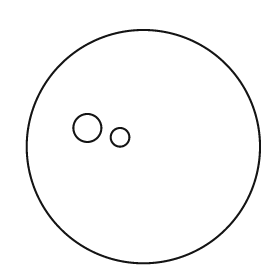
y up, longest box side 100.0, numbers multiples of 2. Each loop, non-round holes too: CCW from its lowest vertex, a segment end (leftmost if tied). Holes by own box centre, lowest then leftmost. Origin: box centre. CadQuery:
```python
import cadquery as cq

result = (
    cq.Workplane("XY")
    .moveTo(0.0, 0.0)
    .circle(50.0)
    .moveTo(-10.0, 4.0)
    .circle(4.0)
    .moveTo(-24.0, 8.0)
    .circle(6.0)
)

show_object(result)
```